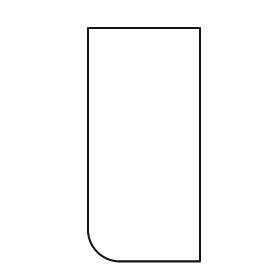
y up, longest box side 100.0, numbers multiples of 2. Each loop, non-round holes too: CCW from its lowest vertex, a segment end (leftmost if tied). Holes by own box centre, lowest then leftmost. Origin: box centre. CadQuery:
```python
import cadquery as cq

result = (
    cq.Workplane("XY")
    .moveTo(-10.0, -50.0)
    .lineTo(24.0, -50.0)
    .lineTo(24.0, 50.0)
    .lineTo(-24.0, 50.0)
    .lineTo(-24.0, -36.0)
    .threePointArc((-20.0, -46.0), (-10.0, -50.0))
    .close()
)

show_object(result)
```